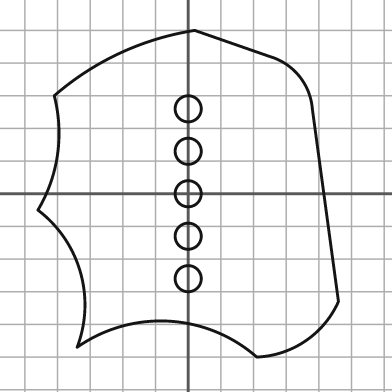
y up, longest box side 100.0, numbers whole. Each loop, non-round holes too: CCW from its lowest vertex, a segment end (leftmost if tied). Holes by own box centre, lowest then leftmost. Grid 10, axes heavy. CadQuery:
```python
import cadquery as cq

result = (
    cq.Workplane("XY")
    .moveTo(21.0, -50.0)
    .threePointArc((36.0, -45.0), (46.0, -33.0))
    .lineTo(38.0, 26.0)
    .threePointArc((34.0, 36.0), (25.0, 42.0))
    .lineTo(2.0, 50.0)
    .threePointArc((-21.0, 43.0), (-41.0, 30.0))
    .threePointArc((-40.0, 12.0), (-46.0, -5.0))
    .threePointArc((-33.0, -24.0), (-34.0, -47.0))
    .threePointArc((-6.0, -39.0), (21.0, -50.0))
    .close()
    .moveTo(0.0, -26.0)
    .circle(4.0)
    .moveTo(0.0, -13.0)
    .circle(4.0)
    .moveTo(0.0, 0.0)
    .circle(4.0)
    .moveTo(0.0, 13.0)
    .circle(4.0)
    .moveTo(0.0, 26.0)
    .circle(4.0)
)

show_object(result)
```